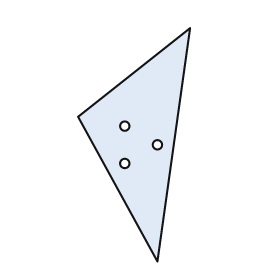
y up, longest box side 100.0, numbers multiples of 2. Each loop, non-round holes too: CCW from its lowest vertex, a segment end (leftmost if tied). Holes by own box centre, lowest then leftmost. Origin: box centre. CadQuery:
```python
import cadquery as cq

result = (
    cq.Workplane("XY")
    .moveTo(10.0, -50.0)
    .lineTo(24.0, 50.0)
    .lineTo(-24.0, 12.0)
    .close()
    .moveTo(-4.0, -8.0)
    .circle(2.0)
    .moveTo(10.0, 0.0)
    .circle(2.0)
    .moveTo(-4.0, 8.0)
    .circle(2.0)
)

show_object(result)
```